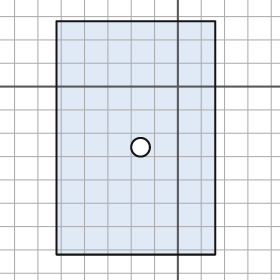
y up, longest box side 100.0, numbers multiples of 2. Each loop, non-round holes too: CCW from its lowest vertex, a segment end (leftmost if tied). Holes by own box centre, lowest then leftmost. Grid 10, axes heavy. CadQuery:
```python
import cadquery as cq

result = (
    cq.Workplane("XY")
    .moveTo(-52.0, -72.0)
    .lineTo(16.0, -72.0)
    .lineTo(16.0, 28.0)
    .lineTo(-52.0, 28.0)
    .close()
    .moveTo(-16.0, -26.0)
    .circle(4.0)
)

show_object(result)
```